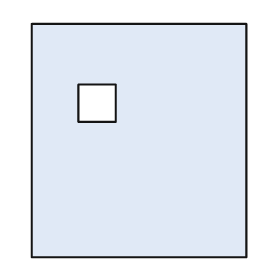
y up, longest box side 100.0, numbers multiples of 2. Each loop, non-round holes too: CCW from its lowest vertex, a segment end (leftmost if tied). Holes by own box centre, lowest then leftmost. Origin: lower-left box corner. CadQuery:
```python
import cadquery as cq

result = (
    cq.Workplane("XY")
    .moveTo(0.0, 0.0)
    .lineTo(92.0, 0.0)
    .lineTo(92.0, 100.0)
    .lineTo(0.0, 100.0)
    .close()
    .moveTo(20.0, 58.0)
    .lineTo(36.0, 58.0)
    .lineTo(36.0, 74.0)
    .lineTo(20.0, 74.0)
    .close()
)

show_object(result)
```